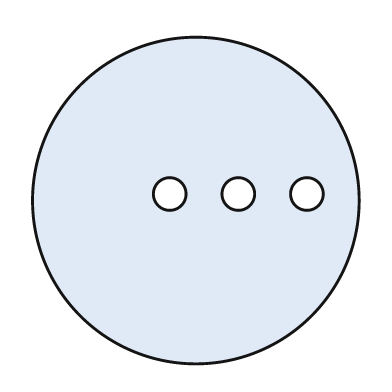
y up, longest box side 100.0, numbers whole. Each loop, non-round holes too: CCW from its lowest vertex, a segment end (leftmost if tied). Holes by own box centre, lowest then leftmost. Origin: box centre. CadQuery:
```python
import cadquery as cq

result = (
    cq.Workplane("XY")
    .moveTo(0.0, 0.0)
    .circle(50.0)
    .moveTo(-8.0, 2.0)
    .circle(5.0)
    .moveTo(13.0, 2.0)
    .circle(5.0)
    .moveTo(34.0, 2.0)
    .circle(5.0)
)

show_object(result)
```